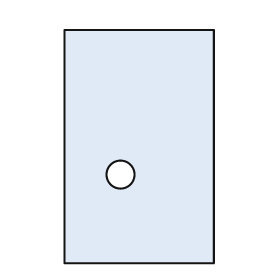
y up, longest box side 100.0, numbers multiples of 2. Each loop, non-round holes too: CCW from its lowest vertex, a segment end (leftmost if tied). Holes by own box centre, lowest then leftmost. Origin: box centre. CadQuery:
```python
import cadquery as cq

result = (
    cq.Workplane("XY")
    .moveTo(-32.0, -50.0)
    .lineTo(32.0, -50.0)
    .lineTo(32.0, 50.0)
    .lineTo(-32.0, 50.0)
    .close()
    .moveTo(-8.0, -12.0)
    .circle(6.0)
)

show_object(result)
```